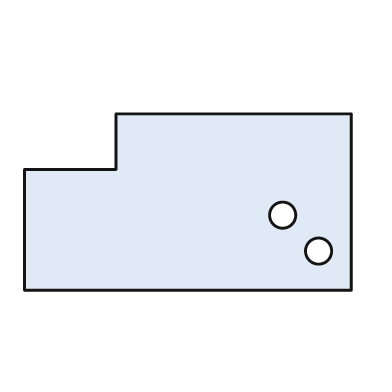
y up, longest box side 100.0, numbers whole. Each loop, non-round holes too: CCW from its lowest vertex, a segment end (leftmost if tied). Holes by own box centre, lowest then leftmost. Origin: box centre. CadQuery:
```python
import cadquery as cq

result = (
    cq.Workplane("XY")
    .moveTo(-50.0, -27.0)
    .lineTo(50.0, -27.0)
    .lineTo(50.0, 27.0)
    .lineTo(-22.0, 27.0)
    .lineTo(-22.0, 10.0)
    .lineTo(-50.0, 10.0)
    .close()
    .moveTo(40.0, -15.0)
    .circle(4.0)
    .moveTo(29.0, -4.0)
    .circle(4.0)
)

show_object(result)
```